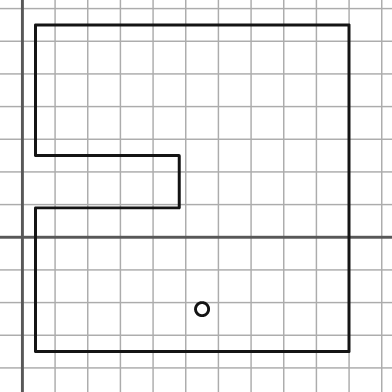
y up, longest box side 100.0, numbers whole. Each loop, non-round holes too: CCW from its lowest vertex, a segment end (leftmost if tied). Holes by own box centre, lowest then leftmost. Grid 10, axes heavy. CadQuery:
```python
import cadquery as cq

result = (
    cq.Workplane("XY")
    .moveTo(4.0, -35.0)
    .lineTo(100.0, -35.0)
    .lineTo(100.0, 65.0)
    .lineTo(4.0, 65.0)
    .lineTo(4.0, 25.0)
    .lineTo(48.0, 25.0)
    .lineTo(48.0, 9.0)
    .lineTo(4.0, 9.0)
    .close()
    .moveTo(55.0, -22.0)
    .circle(2.0)
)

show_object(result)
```